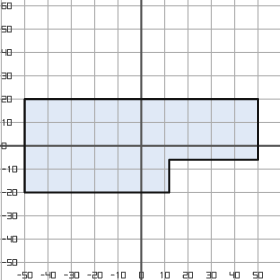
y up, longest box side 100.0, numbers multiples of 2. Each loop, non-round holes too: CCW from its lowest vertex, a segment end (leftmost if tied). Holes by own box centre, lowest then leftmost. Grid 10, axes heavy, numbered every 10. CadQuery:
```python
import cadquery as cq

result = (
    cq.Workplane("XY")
    .moveTo(-50.0, -20.0)
    .lineTo(12.0, -20.0)
    .lineTo(12.0, -6.0)
    .lineTo(50.0, -6.0)
    .lineTo(50.0, 20.0)
    .lineTo(-50.0, 20.0)
    .close()
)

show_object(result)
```